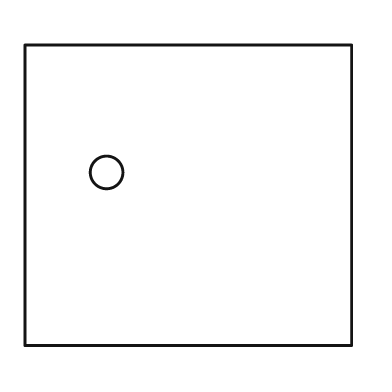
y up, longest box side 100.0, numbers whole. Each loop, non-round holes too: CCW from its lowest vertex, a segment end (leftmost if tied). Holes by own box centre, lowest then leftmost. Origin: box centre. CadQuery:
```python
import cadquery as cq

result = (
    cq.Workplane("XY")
    .moveTo(-50.0, -46.0)
    .lineTo(50.0, -46.0)
    .lineTo(50.0, 46.0)
    .lineTo(-50.0, 46.0)
    .close()
    .moveTo(-25.0, 7.0)
    .circle(5.0)
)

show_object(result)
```